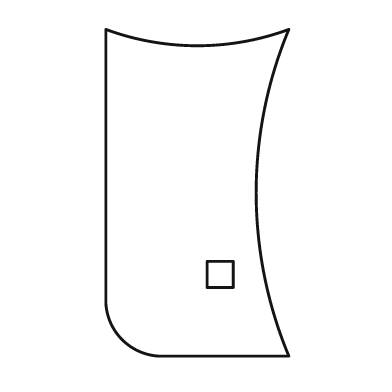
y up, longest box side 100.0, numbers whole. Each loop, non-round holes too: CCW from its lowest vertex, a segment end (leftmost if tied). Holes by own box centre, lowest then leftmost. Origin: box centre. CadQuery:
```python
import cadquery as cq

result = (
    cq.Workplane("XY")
    .moveTo(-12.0, -50.0)
    .lineTo(28.0, -50.0)
    .threePointArc((18.0, 0.0), (28.0, 50.0))
    .threePointArc((0.0, 45.0), (-28.0, 50.0))
    .lineTo(-28.0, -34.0)
    .threePointArc((-23.0, -45.0), (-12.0, -50.0))
    .close()
    .moveTo(3.0, -29.0)
    .lineTo(11.0, -29.0)
    .lineTo(11.0, -21.0)
    .lineTo(3.0, -21.0)
    .close()
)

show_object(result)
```